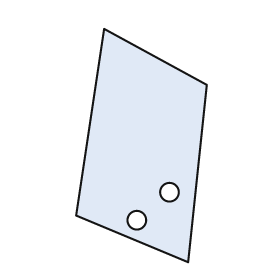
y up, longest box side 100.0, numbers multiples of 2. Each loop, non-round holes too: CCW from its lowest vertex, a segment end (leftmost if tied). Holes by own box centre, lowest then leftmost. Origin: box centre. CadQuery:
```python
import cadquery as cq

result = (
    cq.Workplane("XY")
    .moveTo(20.0, -50.0)
    .lineTo(28.0, 26.0)
    .lineTo(-16.0, 50.0)
    .lineTo(-28.0, -30.0)
    .close()
    .moveTo(-2.0, -32.0)
    .circle(4.0)
    .moveTo(12.0, -20.0)
    .circle(4.0)
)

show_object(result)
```